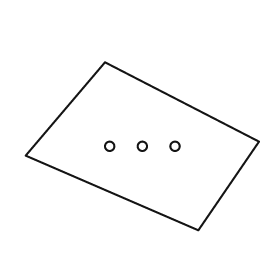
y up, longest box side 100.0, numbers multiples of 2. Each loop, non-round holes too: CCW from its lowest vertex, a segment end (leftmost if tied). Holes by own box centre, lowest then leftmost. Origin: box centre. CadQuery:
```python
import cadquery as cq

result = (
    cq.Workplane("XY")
    .moveTo(24.0, -36.0)
    .lineTo(50.0, 2.0)
    .lineTo(-16.0, 36.0)
    .lineTo(-50.0, -4.0)
    .close()
    .moveTo(-14.0, 0.0)
    .circle(2.0)
    .moveTo(0.0, 0.0)
    .circle(2.0)
    .moveTo(14.0, 0.0)
    .circle(2.0)
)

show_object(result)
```